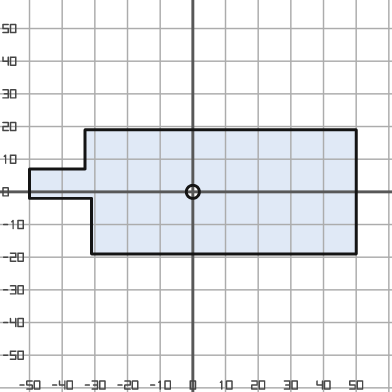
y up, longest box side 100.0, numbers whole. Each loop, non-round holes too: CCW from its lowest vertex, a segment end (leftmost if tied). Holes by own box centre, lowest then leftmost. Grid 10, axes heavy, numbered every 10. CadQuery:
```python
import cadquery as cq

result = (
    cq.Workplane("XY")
    .moveTo(-31.0, -19.0)
    .lineTo(50.0, -19.0)
    .lineTo(50.0, 19.0)
    .lineTo(-33.0, 19.0)
    .lineTo(-33.0, 7.0)
    .lineTo(-50.0, 7.0)
    .lineTo(-50.0, -2.0)
    .lineTo(-31.0, -2.0)
    .close()
    .moveTo(0.0, 0.0)
    .circle(2.0)
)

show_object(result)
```